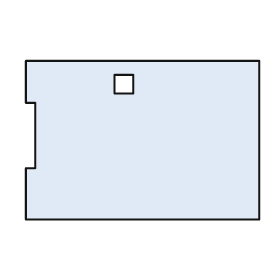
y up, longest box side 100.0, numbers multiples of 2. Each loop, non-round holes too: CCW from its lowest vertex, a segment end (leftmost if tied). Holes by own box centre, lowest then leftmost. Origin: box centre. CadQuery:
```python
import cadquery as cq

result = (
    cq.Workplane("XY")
    .moveTo(-50.0, -34.0)
    .lineTo(50.0, -34.0)
    .lineTo(50.0, 34.0)
    .lineTo(-50.0, 34.0)
    .lineTo(-50.0, 16.0)
    .lineTo(-46.0, 16.0)
    .lineTo(-46.0, -12.0)
    .lineTo(-50.0, -12.0)
    .close()
    .moveTo(-12.0, 20.0)
    .lineTo(-4.0, 20.0)
    .lineTo(-4.0, 28.0)
    .lineTo(-12.0, 28.0)
    .close()
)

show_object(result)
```